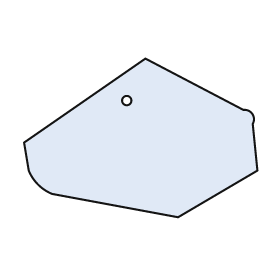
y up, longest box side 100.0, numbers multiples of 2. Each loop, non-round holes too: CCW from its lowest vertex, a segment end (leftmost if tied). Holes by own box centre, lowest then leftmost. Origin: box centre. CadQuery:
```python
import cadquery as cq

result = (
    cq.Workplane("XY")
    .moveTo(16.0, -34.0)
    .lineTo(50.0, -14.0)
    .lineTo(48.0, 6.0)
    .threePointArc((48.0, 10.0), (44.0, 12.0))
    .lineTo(2.0, 34.0)
    .lineTo(-50.0, -2.0)
    .lineTo(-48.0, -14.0)
    .threePointArc((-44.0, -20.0), (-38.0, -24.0))
    .close()
    .moveTo(-6.0, 16.0)
    .circle(2.0)
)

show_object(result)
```